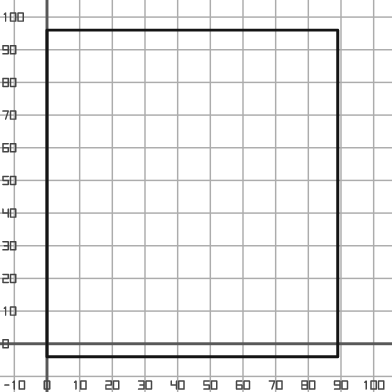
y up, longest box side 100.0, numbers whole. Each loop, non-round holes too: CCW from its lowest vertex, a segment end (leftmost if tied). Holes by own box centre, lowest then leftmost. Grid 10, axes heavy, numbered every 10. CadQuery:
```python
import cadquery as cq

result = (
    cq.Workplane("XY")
    .moveTo(0.0, -4.0)
    .lineTo(89.0, -4.0)
    .lineTo(89.0, 96.0)
    .lineTo(0.0, 96.0)
    .close()
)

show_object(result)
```